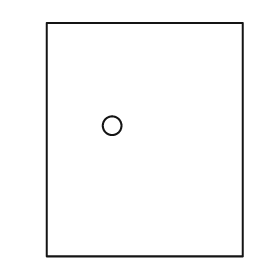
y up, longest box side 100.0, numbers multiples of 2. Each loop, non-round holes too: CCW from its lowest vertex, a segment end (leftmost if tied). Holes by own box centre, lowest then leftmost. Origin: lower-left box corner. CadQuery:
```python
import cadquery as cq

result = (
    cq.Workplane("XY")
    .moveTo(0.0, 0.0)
    .lineTo(84.0, 0.0)
    .lineTo(84.0, 100.0)
    .lineTo(0.0, 100.0)
    .close()
    .moveTo(28.0, 56.0)
    .circle(4.0)
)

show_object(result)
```